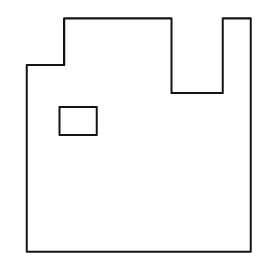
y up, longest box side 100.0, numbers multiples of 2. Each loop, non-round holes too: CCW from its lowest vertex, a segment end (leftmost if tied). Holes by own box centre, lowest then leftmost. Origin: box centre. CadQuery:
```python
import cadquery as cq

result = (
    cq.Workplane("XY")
    .moveTo(-48.0, -50.0)
    .lineTo(48.0, -50.0)
    .lineTo(48.0, 50.0)
    .lineTo(36.0, 50.0)
    .lineTo(36.0, 18.0)
    .lineTo(14.0, 18.0)
    .lineTo(14.0, 50.0)
    .lineTo(-32.0, 50.0)
    .lineTo(-32.0, 30.0)
    .lineTo(-48.0, 30.0)
    .close()
    .moveTo(-34.0, 0.0)
    .lineTo(-18.0, 0.0)
    .lineTo(-18.0, 12.0)
    .lineTo(-34.0, 12.0)
    .close()
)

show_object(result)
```